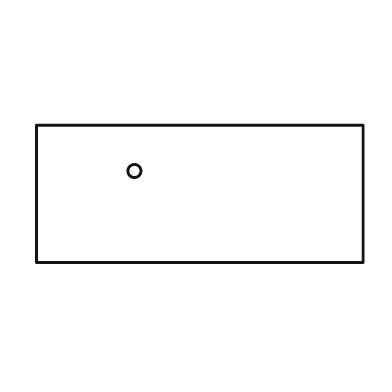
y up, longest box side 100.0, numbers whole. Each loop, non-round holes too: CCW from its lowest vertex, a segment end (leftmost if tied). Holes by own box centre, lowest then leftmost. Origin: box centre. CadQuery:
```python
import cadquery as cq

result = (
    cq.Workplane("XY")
    .moveTo(-50.0, -21.0)
    .lineTo(50.0, -21.0)
    .lineTo(50.0, 21.0)
    .lineTo(-50.0, 21.0)
    .close()
    .moveTo(-20.0, 7.0)
    .circle(2.0)
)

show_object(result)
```